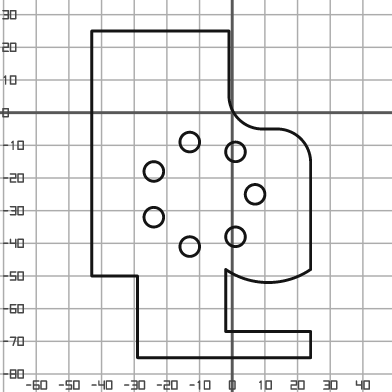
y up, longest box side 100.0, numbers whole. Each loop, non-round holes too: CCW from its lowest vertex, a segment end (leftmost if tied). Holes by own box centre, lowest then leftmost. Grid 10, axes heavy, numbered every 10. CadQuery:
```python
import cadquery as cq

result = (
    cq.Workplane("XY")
    .moveTo(-29.0, -75.0)
    .lineTo(24.0, -75.0)
    .lineTo(24.0, -67.0)
    .lineTo(-2.0, -67.0)
    .lineTo(-2.0, -48.0)
    .threePointArc((11.0, -52.0), (24.0, -48.0))
    .lineTo(24.0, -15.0)
    .threePointArc((21.0, -8.0), (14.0, -5.0))
    .lineTo(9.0, -5.0)
    .threePointArc((2.0, -2.0), (-1.0, 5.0))
    .lineTo(-1.0, 25.0)
    .lineTo(-43.0, 25.0)
    .lineTo(-43.0, -50.0)
    .lineTo(-29.0, -50.0)
    .close()
    .moveTo(-13.0, -41.0)
    .circle(3.0)
    .moveTo(1.0, -38.0)
    .circle(3.0)
    .moveTo(-24.0, -32.0)
    .circle(3.0)
    .moveTo(7.0, -25.0)
    .circle(3.0)
    .moveTo(-24.0, -18.0)
    .circle(3.0)
    .moveTo(1.0, -12.0)
    .circle(3.0)
    .moveTo(-13.0, -9.0)
    .circle(3.0)
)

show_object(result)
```